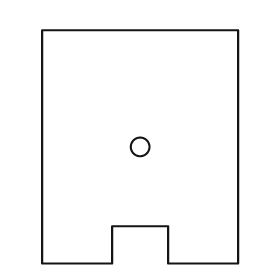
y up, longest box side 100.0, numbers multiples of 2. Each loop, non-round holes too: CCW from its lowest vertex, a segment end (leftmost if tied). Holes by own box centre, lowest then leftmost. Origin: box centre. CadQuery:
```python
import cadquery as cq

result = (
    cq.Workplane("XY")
    .moveTo(-42.0, -50.0)
    .lineTo(-12.0, -50.0)
    .lineTo(-12.0, -34.0)
    .lineTo(12.0, -34.0)
    .lineTo(12.0, -50.0)
    .lineTo(42.0, -50.0)
    .lineTo(42.0, 50.0)
    .lineTo(-42.0, 50.0)
    .close()
    .moveTo(0.0, 0.0)
    .circle(4.0)
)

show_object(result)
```